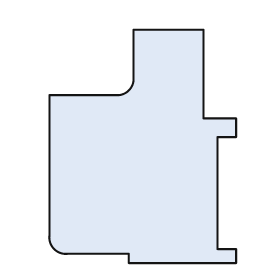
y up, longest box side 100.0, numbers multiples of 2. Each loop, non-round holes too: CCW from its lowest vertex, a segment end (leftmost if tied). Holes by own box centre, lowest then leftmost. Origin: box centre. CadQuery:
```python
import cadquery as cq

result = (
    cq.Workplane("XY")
    .moveTo(-6.0, -50.0)
    .lineTo(40.0, -50.0)
    .lineTo(40.0, -44.0)
    .lineTo(32.0, -44.0)
    .lineTo(32.0, 4.0)
    .lineTo(40.0, 4.0)
    .lineTo(40.0, 12.0)
    .lineTo(26.0, 12.0)
    .lineTo(26.0, 50.0)
    .lineTo(-4.0, 50.0)
    .lineTo(-4.0, 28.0)
    .threePointArc((-6.0, 24.0), (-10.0, 22.0))
    .lineTo(-40.0, 22.0)
    .lineTo(-40.0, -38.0)
    .threePointArc((-38.0, -44.0), (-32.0, -46.0))
    .lineTo(-6.0, -46.0)
    .close()
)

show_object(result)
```